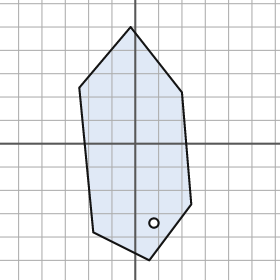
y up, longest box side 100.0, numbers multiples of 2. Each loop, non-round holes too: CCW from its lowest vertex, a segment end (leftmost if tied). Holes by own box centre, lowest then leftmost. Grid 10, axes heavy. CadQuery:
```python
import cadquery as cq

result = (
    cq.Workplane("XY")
    .moveTo(6.0, -50.0)
    .lineTo(24.0, -26.0)
    .lineTo(20.0, 22.0)
    .lineTo(-2.0, 50.0)
    .lineTo(-24.0, 24.0)
    .lineTo(-18.0, -38.0)
    .close()
    .moveTo(8.0, -34.0)
    .circle(2.0)
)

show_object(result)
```